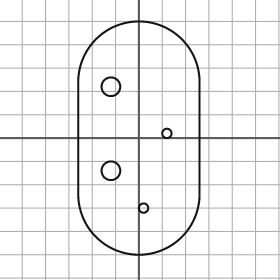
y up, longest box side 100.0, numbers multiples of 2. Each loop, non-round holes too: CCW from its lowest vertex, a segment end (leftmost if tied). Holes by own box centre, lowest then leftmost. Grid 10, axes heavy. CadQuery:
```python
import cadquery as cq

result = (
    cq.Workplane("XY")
    .moveTo(-26.0, -24.0)
    .threePointArc((0.0, -50.0), (26.0, -24.0))
    .lineTo(26.0, 24.0)
    .threePointArc((0.0, 50.0), (-26.0, 24.0))
    .close()
    .moveTo(2.0, -30.0)
    .circle(2.0)
    .moveTo(-12.0, -14.0)
    .circle(4.0)
    .moveTo(12.0, 2.0)
    .circle(2.0)
    .moveTo(-12.0, 22.0)
    .circle(4.0)
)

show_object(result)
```